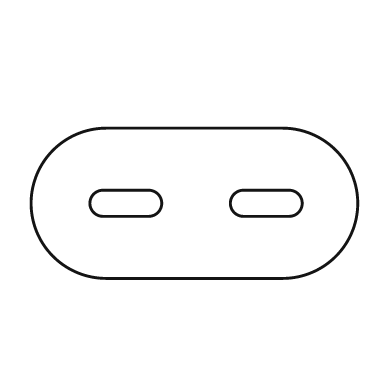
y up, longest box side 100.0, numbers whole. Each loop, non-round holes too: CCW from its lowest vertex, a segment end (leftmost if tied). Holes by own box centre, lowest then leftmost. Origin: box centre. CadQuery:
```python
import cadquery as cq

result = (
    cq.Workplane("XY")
    .moveTo(-27.0, -23.0)
    .lineTo(27.0, -23.0)
    .threePointArc((50.0, 0.0), (27.0, 23.0))
    .lineTo(-27.0, 23.0)
    .threePointArc((-50.0, 0.0), (-27.0, -23.0))
    .close()
    .moveTo(-28.0, -4.0)
    .lineTo(-14.0, -4.0)
    .threePointArc((-10.0, 0.0), (-14.0, 4.0))
    .lineTo(-28.0, 4.0)
    .threePointArc((-32.0, 0.0), (-28.0, -4.0))
    .close()
    .moveTo(15.0, -4.0)
    .lineTo(29.0, -4.0)
    .threePointArc((33.0, 0.0), (29.0, 4.0))
    .lineTo(15.0, 4.0)
    .threePointArc((11.0, 0.0), (15.0, -4.0))
    .close()
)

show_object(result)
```